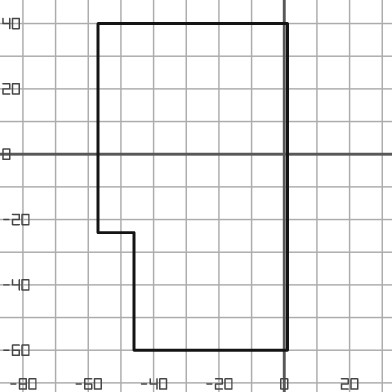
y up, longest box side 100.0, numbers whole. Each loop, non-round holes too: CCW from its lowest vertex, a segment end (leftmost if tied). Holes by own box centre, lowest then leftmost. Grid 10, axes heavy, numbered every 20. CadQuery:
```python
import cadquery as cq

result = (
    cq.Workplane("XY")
    .moveTo(-46.0, -60.0)
    .lineTo(1.0, -60.0)
    .lineTo(1.0, 40.0)
    .lineTo(-57.0, 40.0)
    .lineTo(-57.0, -24.0)
    .lineTo(-46.0, -24.0)
    .close()
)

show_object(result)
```